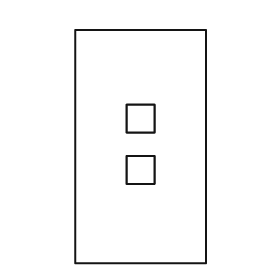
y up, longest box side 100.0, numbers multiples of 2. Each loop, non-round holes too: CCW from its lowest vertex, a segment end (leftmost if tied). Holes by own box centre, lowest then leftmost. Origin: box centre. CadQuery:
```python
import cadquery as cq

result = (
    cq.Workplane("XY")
    .moveTo(-28.0, -50.0)
    .lineTo(28.0, -50.0)
    .lineTo(28.0, 50.0)
    .lineTo(-28.0, 50.0)
    .close()
    .moveTo(-6.0, -16.0)
    .lineTo(6.0, -16.0)
    .lineTo(6.0, -4.0)
    .lineTo(-6.0, -4.0)
    .close()
    .moveTo(-6.0, 6.0)
    .lineTo(6.0, 6.0)
    .lineTo(6.0, 18.0)
    .lineTo(-6.0, 18.0)
    .close()
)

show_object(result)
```